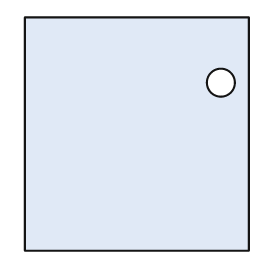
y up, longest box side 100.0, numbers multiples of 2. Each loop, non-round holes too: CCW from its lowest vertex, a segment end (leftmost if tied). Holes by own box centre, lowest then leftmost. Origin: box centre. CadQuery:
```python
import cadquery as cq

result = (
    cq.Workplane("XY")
    .moveTo(-48.0, -50.0)
    .lineTo(48.0, -50.0)
    .lineTo(48.0, 50.0)
    .lineTo(-48.0, 50.0)
    .close()
    .moveTo(36.0, 22.0)
    .circle(6.0)
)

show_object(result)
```